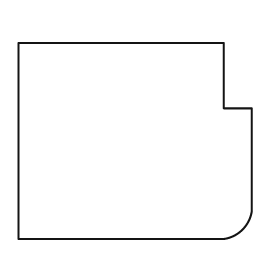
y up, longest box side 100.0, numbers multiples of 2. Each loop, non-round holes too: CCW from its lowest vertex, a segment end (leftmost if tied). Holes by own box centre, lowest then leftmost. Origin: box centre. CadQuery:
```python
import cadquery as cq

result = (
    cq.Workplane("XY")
    .moveTo(-50.0, -42.0)
    .lineTo(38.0, -42.0)
    .threePointArc((46.0, -38.0), (50.0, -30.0))
    .lineTo(50.0, 14.0)
    .lineTo(38.0, 14.0)
    .lineTo(38.0, 42.0)
    .lineTo(-50.0, 42.0)
    .close()
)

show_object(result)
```